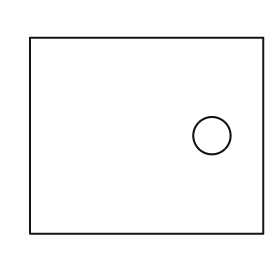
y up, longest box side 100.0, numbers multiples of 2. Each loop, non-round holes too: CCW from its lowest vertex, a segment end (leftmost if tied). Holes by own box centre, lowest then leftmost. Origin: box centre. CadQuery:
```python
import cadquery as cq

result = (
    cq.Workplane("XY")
    .moveTo(-50.0, -42.0)
    .lineTo(50.0, -42.0)
    .lineTo(50.0, 42.0)
    .lineTo(-50.0, 42.0)
    .close()
    .moveTo(28.0, 0.0)
    .circle(8.0)
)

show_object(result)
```